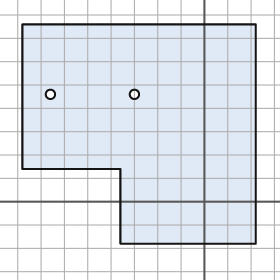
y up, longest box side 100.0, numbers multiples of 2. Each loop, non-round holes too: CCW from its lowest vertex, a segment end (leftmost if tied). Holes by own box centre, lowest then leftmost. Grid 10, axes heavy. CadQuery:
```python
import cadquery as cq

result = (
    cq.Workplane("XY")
    .moveTo(-36.0, -18.0)
    .lineTo(22.0, -18.0)
    .lineTo(22.0, 76.0)
    .lineTo(-78.0, 76.0)
    .lineTo(-78.0, 14.0)
    .lineTo(-36.0, 14.0)
    .close()
    .moveTo(-66.0, 46.0)
    .circle(2.0)
    .moveTo(-30.0, 46.0)
    .circle(2.0)
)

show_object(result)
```